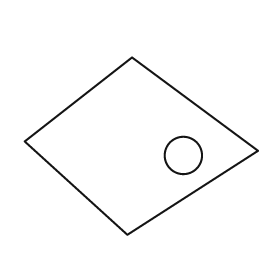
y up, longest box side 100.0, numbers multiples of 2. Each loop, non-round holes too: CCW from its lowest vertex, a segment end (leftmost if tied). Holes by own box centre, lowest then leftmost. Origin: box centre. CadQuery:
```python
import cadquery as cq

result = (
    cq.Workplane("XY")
    .moveTo(-6.0, -38.0)
    .lineTo(50.0, -2.0)
    .lineTo(-4.0, 38.0)
    .lineTo(-50.0, 2.0)
    .close()
    .moveTo(18.0, -4.0)
    .circle(8.0)
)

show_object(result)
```